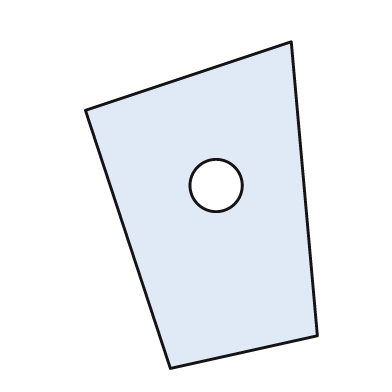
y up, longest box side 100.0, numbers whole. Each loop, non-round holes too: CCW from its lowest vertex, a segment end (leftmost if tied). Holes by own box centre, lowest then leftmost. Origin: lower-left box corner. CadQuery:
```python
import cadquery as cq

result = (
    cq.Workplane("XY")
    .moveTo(26.0, 0.0)
    .lineTo(71.0, 10.0)
    .lineTo(63.0, 100.0)
    .lineTo(0.0, 79.0)
    .close()
    .moveTo(40.0, 56.0)
    .circle(8.0)
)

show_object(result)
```